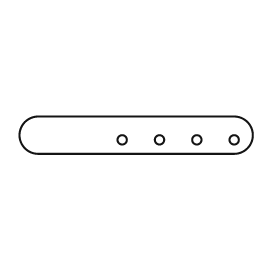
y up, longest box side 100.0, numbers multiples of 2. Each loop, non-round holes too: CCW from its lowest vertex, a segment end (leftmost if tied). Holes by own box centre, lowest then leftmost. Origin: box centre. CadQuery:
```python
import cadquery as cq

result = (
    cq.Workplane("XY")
    .moveTo(-42.0, -8.0)
    .lineTo(42.0, -8.0)
    .threePointArc((50.0, 0.0), (42.0, 8.0))
    .lineTo(-42.0, 8.0)
    .threePointArc((-50.0, 0.0), (-42.0, -8.0))
    .close()
    .moveTo(-6.0, -2.0)
    .circle(2.0)
    .moveTo(10.0, -2.0)
    .circle(2.0)
    .moveTo(26.0, -2.0)
    .circle(2.0)
    .moveTo(42.0, -2.0)
    .circle(2.0)
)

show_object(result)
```